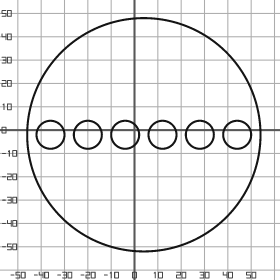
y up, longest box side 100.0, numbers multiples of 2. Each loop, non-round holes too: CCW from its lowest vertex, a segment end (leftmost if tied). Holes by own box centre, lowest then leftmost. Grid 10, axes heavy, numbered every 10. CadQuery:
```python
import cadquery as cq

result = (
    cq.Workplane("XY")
    .moveTo(4.0, -2.0)
    .circle(50.0)
    .moveTo(-36.0, -2.0)
    .circle(6.0)
    .moveTo(-20.0, -2.0)
    .circle(6.0)
    .moveTo(-4.0, -2.0)
    .circle(6.0)
    .moveTo(12.0, -2.0)
    .circle(6.0)
    .moveTo(28.0, -2.0)
    .circle(6.0)
    .moveTo(44.0, -2.0)
    .circle(6.0)
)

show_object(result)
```